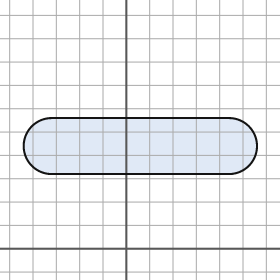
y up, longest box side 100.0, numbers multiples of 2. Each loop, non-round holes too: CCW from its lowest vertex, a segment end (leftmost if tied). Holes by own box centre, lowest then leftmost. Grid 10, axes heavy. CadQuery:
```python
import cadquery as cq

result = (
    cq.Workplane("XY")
    .moveTo(-32.0, 32.0)
    .lineTo(44.0, 32.0)
    .threePointArc((56.0, 44.0), (44.0, 56.0))
    .lineTo(-32.0, 56.0)
    .threePointArc((-44.0, 44.0), (-32.0, 32.0))
    .close()
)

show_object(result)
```